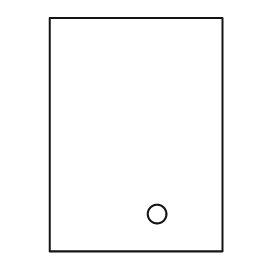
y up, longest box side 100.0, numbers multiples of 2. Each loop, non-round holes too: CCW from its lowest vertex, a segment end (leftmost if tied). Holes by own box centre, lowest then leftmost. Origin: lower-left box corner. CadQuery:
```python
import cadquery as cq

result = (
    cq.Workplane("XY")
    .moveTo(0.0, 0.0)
    .lineTo(74.0, 0.0)
    .lineTo(74.0, 100.0)
    .lineTo(0.0, 100.0)
    .close()
    .moveTo(46.0, 16.0)
    .circle(4.0)
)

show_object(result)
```